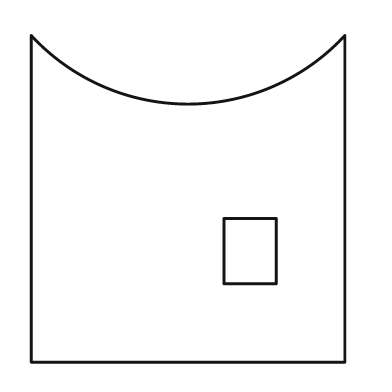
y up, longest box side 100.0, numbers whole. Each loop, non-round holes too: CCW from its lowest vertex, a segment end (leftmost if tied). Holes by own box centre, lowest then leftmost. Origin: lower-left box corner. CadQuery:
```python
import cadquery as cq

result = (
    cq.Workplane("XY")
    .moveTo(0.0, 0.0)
    .lineTo(96.0, 0.0)
    .lineTo(96.0, 100.0)
    .threePointArc((48.0, 79.0), (0.0, 100.0))
    .close()
    .moveTo(59.0, 24.0)
    .lineTo(75.0, 24.0)
    .lineTo(75.0, 44.0)
    .lineTo(59.0, 44.0)
    .close()
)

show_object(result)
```